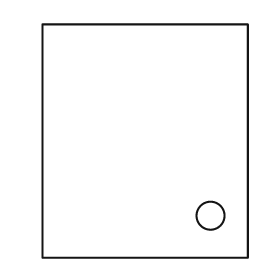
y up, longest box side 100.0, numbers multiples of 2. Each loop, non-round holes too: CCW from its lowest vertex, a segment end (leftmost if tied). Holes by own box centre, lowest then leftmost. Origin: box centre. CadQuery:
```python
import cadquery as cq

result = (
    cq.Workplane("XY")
    .moveTo(-44.0, -50.0)
    .lineTo(44.0, -50.0)
    .lineTo(44.0, 50.0)
    .lineTo(-44.0, 50.0)
    .close()
    .moveTo(28.0, -32.0)
    .circle(6.0)
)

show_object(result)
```